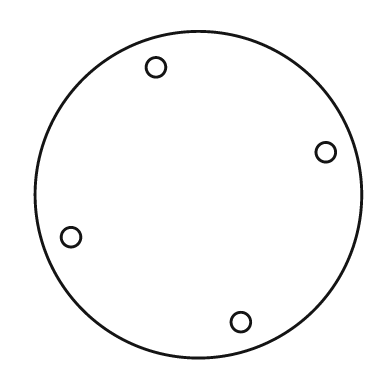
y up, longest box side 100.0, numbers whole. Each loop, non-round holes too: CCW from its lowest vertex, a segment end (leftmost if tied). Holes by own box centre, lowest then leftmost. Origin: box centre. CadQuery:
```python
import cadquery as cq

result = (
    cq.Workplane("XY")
    .moveTo(0.0, 0.0)
    .circle(50.0)
    .moveTo(13.0, -39.0)
    .circle(3.0)
    .moveTo(-39.0, -13.0)
    .circle(3.0)
    .moveTo(39.0, 13.0)
    .circle(3.0)
    .moveTo(-13.0, 39.0)
    .circle(3.0)
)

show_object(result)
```